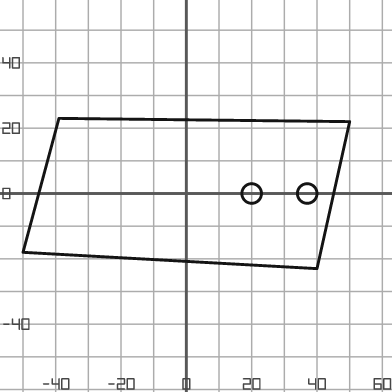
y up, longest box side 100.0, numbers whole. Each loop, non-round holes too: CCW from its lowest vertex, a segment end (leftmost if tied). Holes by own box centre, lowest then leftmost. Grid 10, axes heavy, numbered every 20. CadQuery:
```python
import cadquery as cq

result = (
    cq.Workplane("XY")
    .moveTo(40.0, -23.0)
    .lineTo(50.0, 22.0)
    .lineTo(-39.0, 23.0)
    .lineTo(-50.0, -18.0)
    .close()
    .moveTo(20.0, 0.0)
    .circle(3.0)
    .moveTo(37.0, 0.0)
    .circle(3.0)
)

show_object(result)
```